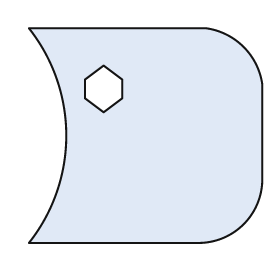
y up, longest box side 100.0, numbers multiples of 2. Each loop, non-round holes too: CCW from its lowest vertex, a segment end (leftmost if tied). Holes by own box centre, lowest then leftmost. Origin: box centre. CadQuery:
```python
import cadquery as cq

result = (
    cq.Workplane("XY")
    .moveTo(-50.0, -46.0)
    .lineTo(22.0, -46.0)
    .threePointArc((42.0, -38.0), (50.0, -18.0))
    .lineTo(50.0, 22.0)
    .threePointArc((42.0, 38.0), (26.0, 46.0))
    .lineTo(-50.0, 46.0)
    .threePointArc((-34.0, 0.0), (-50.0, -46.0))
    .close()
    .moveTo(-18.0, 10.0)
    .lineTo(-10.0, 16.0)
    .lineTo(-10.0, 24.0)
    .lineTo(-18.0, 30.0)
    .lineTo(-26.0, 24.0)
    .lineTo(-26.0, 16.0)
    .close()
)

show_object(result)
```